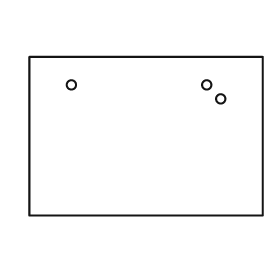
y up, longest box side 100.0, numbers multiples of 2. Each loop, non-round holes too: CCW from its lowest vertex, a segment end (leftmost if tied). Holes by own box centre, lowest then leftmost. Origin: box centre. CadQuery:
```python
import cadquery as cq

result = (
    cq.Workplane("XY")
    .moveTo(-50.0, -34.0)
    .lineTo(50.0, -34.0)
    .lineTo(50.0, 34.0)
    .lineTo(-50.0, 34.0)
    .close()
    .moveTo(32.0, 16.0)
    .circle(2.0)
    .moveTo(-32.0, 22.0)
    .circle(2.0)
    .moveTo(26.0, 22.0)
    .circle(2.0)
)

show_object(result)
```